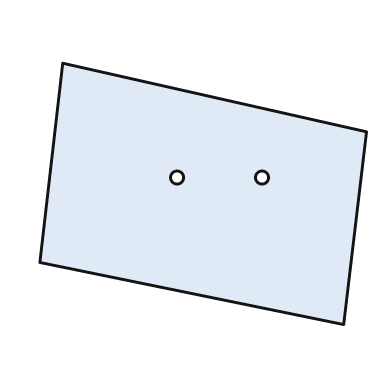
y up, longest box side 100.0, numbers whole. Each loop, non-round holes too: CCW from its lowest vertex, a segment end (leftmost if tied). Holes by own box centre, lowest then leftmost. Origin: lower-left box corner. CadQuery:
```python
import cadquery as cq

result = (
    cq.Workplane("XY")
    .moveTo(93.0, 0.0)
    .lineTo(100.0, 59.0)
    .lineTo(7.0, 80.0)
    .lineTo(0.0, 19.0)
    .close()
    .moveTo(42.0, 45.0)
    .circle(2.0)
    .moveTo(68.0, 45.0)
    .circle(2.0)
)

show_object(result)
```